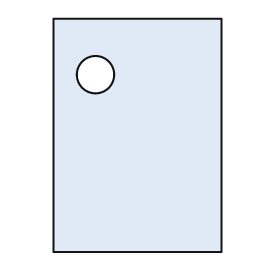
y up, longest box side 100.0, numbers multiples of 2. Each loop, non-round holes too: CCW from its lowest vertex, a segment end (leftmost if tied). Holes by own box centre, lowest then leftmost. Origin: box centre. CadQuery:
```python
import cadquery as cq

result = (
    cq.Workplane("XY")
    .moveTo(-36.0, -50.0)
    .lineTo(36.0, -50.0)
    .lineTo(36.0, 50.0)
    .lineTo(-36.0, 50.0)
    .close()
    .moveTo(-18.0, 26.0)
    .circle(8.0)
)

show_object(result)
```